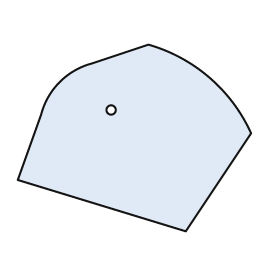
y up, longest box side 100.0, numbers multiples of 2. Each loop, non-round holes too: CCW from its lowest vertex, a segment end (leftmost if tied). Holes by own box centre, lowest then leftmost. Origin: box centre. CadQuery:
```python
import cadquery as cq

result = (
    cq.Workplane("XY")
    .moveTo(22.0, -40.0)
    .lineTo(50.0, 2.0)
    .threePointArc((32.0, 26.0), (6.0, 40.0))
    .lineTo(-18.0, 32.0)
    .threePointArc((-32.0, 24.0), (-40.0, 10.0))
    .lineTo(-50.0, -18.0)
    .close()
    .moveTo(-10.0, 12.0)
    .circle(2.0)
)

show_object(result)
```